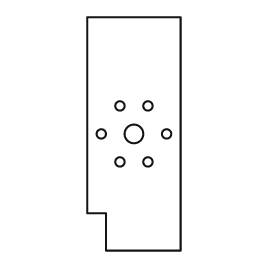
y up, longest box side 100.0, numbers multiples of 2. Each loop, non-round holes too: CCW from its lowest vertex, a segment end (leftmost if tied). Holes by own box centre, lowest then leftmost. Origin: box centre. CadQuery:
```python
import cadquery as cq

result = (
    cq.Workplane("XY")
    .moveTo(-12.0, -50.0)
    .lineTo(20.0, -50.0)
    .lineTo(20.0, 50.0)
    .lineTo(-20.0, 50.0)
    .lineTo(-20.0, -34.0)
    .lineTo(-12.0, -34.0)
    .close()
    .moveTo(-6.0, -12.0)
    .circle(2.0)
    .moveTo(6.0, -12.0)
    .circle(2.0)
    .moveTo(-14.0, 0.0)
    .circle(2.0)
    .moveTo(0.0, 0.0)
    .circle(4.0)
    .moveTo(14.0, 0.0)
    .circle(2.0)
    .moveTo(-6.0, 12.0)
    .circle(2.0)
    .moveTo(6.0, 12.0)
    .circle(2.0)
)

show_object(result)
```